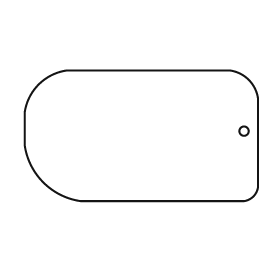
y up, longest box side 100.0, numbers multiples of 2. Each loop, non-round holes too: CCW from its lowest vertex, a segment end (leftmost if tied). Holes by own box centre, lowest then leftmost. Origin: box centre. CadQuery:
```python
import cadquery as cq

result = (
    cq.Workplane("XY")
    .moveTo(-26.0, -28.0)
    .lineTo(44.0, -28.0)
    .threePointArc((48.0, -26.0), (50.0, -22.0))
    .lineTo(50.0, 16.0)
    .threePointArc((46.0, 24.0), (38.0, 28.0))
    .lineTo(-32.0, 28.0)
    .threePointArc((-44.0, 22.0), (-50.0, 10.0))
    .lineTo(-50.0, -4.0)
    .threePointArc((-42.0, -20.0), (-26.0, -28.0))
    .close()
    .moveTo(44.0, 2.0)
    .circle(2.0)
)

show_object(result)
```